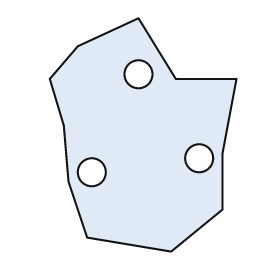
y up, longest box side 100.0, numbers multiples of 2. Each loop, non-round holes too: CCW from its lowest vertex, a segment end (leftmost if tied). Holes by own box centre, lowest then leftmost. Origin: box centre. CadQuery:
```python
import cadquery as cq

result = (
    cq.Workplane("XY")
    .moveTo(12.0, -50.0)
    .lineTo(34.0, -32.0)
    .lineTo(34.0, -8.0)
    .lineTo(40.0, 24.0)
    .lineTo(14.0, 24.0)
    .lineTo(-2.0, 50.0)
    .lineTo(-28.0, 38.0)
    .lineTo(-40.0, 24.0)
    .lineTo(-34.0, 4.0)
    .lineTo(-32.0, -20.0)
    .lineTo(-24.0, -44.0)
    .close()
    .moveTo(-22.0, -16.0)
    .circle(6.0)
    .moveTo(24.0, -10.0)
    .circle(6.0)
    .moveTo(-2.0, 26.0)
    .circle(6.0)
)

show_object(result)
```